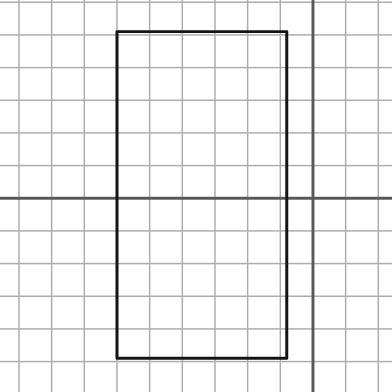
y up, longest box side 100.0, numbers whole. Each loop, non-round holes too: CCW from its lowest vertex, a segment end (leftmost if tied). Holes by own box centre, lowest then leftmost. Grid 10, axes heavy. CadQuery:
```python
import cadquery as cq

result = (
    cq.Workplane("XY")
    .moveTo(-60.0, -49.0)
    .lineTo(-8.0, -49.0)
    .lineTo(-8.0, 51.0)
    .lineTo(-60.0, 51.0)
    .close()
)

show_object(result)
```